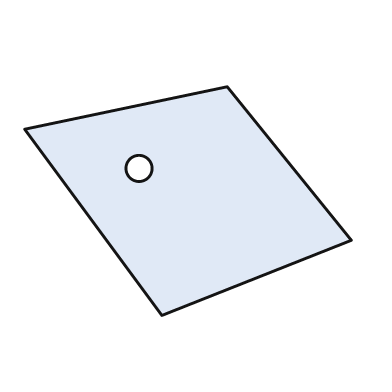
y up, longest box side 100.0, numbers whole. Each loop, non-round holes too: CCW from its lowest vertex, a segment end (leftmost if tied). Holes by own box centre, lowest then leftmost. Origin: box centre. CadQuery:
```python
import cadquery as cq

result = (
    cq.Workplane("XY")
    .moveTo(-8.0, -35.0)
    .lineTo(50.0, -12.0)
    .lineTo(12.0, 35.0)
    .lineTo(-50.0, 22.0)
    .close()
    .moveTo(-15.0, 10.0)
    .circle(4.0)
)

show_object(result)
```